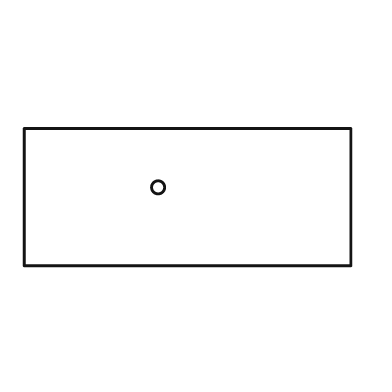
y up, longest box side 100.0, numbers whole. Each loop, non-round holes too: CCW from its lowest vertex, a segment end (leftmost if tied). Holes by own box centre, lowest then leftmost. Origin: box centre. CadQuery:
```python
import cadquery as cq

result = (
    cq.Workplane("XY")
    .moveTo(-50.0, -21.0)
    .lineTo(50.0, -21.0)
    .lineTo(50.0, 21.0)
    .lineTo(-50.0, 21.0)
    .close()
    .moveTo(-9.0, 3.0)
    .circle(2.0)
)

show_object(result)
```